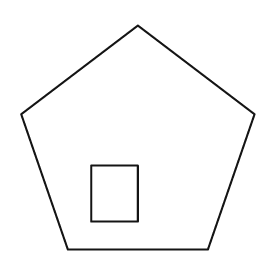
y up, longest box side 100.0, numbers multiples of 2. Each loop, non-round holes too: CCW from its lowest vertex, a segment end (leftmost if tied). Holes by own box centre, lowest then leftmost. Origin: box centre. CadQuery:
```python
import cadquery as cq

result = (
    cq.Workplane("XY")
    .moveTo(-30.0, -48.0)
    .lineTo(30.0, -48.0)
    .lineTo(50.0, 10.0)
    .lineTo(0.0, 48.0)
    .lineTo(-50.0, 10.0)
    .close()
    .moveTo(-20.0, -36.0)
    .lineTo(0.0, -36.0)
    .lineTo(0.0, -12.0)
    .lineTo(-20.0, -12.0)
    .close()
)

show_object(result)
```